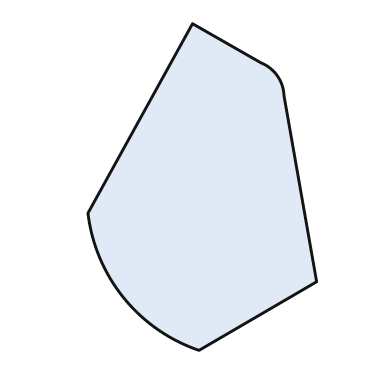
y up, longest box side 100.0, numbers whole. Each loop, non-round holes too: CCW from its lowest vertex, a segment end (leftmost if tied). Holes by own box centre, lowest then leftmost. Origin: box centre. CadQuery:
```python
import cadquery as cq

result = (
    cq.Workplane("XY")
    .moveTo(-1.0, -50.0)
    .lineTo(35.0, -29.0)
    .lineTo(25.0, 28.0)
    .threePointArc((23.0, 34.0), (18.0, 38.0))
    .lineTo(-3.0, 50.0)
    .lineTo(-35.0, -8.0)
    .threePointArc((-24.0, -34.0), (-1.0, -50.0))
    .close()
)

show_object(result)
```